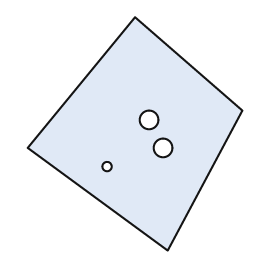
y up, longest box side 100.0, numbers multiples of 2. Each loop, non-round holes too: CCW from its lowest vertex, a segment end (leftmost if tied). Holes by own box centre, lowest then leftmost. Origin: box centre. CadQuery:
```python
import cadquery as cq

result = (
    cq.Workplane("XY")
    .moveTo(14.0, -50.0)
    .lineTo(46.0, 10.0)
    .lineTo(0.0, 50.0)
    .lineTo(-46.0, -6.0)
    .close()
    .moveTo(-12.0, -14.0)
    .circle(2.0)
    .moveTo(12.0, -6.0)
    .circle(4.0)
    .moveTo(6.0, 6.0)
    .circle(4.0)
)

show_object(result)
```